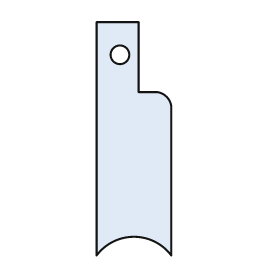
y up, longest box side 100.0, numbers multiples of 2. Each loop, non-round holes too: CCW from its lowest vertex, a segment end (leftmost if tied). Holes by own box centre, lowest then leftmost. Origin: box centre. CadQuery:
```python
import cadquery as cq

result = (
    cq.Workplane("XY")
    .moveTo(-16.0, -50.0)
    .threePointArc((0.0, -42.0), (16.0, -50.0))
    .lineTo(16.0, 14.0)
    .threePointArc((14.0, 18.0), (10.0, 20.0))
    .lineTo(2.0, 20.0)
    .lineTo(2.0, 50.0)
    .lineTo(-16.0, 50.0)
    .close()
    .moveTo(-6.0, 36.0)
    .circle(4.0)
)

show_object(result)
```